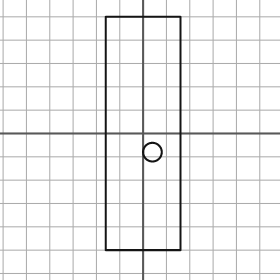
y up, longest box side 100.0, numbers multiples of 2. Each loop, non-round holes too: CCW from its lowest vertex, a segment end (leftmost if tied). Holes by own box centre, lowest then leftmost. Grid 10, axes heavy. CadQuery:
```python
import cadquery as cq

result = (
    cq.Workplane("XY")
    .moveTo(-16.0, -50.0)
    .lineTo(16.0, -50.0)
    .lineTo(16.0, 50.0)
    .lineTo(-16.0, 50.0)
    .close()
    .moveTo(4.0, -8.0)
    .circle(4.0)
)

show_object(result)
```